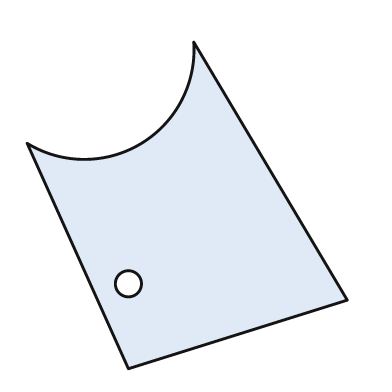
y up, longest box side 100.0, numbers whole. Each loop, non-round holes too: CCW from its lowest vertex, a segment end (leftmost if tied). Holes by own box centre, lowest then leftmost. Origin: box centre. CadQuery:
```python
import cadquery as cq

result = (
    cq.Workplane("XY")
    .moveTo(-18.0, -50.0)
    .lineTo(49.0, -29.0)
    .lineTo(2.0, 50.0)
    .threePointArc((-14.0, 19.0), (-49.0, 19.0))
    .close()
    .moveTo(-18.0, -24.0)
    .circle(4.0)
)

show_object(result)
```